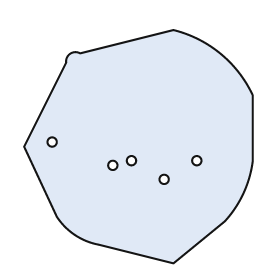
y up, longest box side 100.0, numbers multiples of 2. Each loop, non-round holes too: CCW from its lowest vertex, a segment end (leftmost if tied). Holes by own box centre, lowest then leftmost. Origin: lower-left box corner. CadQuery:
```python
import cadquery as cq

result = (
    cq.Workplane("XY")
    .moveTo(64.0, 0.0)
    .lineTo(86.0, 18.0)
    .threePointArc((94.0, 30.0), (98.0, 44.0))
    .lineTo(98.0, 72.0)
    .threePointArc((84.0, 90.0), (64.0, 100.0))
    .lineTo(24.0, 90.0)
    .threePointArc((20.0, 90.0), (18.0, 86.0))
    .lineTo(0.0, 50.0)
    .lineTo(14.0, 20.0)
    .threePointArc((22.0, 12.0), (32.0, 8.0))
    .close()
    .moveTo(60.0, 36.0)
    .circle(2.0)
    .moveTo(38.0, 42.0)
    .circle(2.0)
    .moveTo(46.0, 44.0)
    .circle(2.0)
    .moveTo(74.0, 44.0)
    .circle(2.0)
    .moveTo(12.0, 52.0)
    .circle(2.0)
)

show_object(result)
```